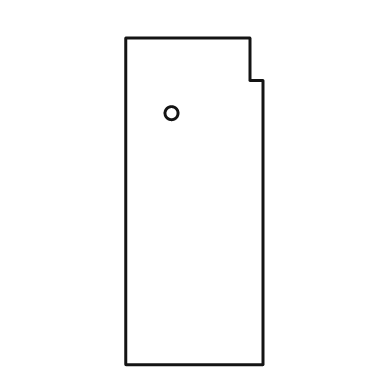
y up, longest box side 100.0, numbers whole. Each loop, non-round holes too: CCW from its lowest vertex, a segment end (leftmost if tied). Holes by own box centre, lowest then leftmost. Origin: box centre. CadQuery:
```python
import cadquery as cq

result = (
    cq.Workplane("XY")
    .moveTo(-21.0, -50.0)
    .lineTo(21.0, -50.0)
    .lineTo(21.0, 37.0)
    .lineTo(17.0, 37.0)
    .lineTo(17.0, 50.0)
    .lineTo(-21.0, 50.0)
    .close()
    .moveTo(-7.0, 27.0)
    .circle(2.0)
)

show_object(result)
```